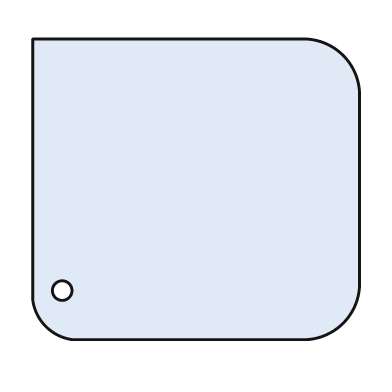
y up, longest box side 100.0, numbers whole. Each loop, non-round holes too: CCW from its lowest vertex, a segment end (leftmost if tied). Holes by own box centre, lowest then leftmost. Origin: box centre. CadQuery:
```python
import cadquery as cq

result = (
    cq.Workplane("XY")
    .moveTo(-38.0, -46.0)
    .lineTo(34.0, -46.0)
    .threePointArc((45.0, -41.0), (50.0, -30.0))
    .lineTo(50.0, 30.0)
    .threePointArc((45.0, 41.0), (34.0, 46.0))
    .lineTo(-50.0, 46.0)
    .lineTo(-50.0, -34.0)
    .threePointArc((-46.0, -42.0), (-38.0, -46.0))
    .close()
    .moveTo(-41.0, -31.0)
    .circle(3.0)
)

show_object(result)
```